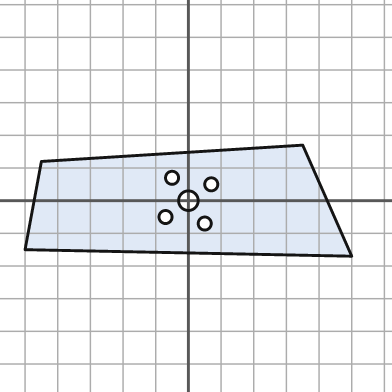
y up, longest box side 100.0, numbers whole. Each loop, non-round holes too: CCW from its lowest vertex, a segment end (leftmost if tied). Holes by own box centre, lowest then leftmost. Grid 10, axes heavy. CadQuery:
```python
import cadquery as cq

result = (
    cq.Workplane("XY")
    .moveTo(50.0, -17.0)
    .lineTo(35.0, 17.0)
    .lineTo(-45.0, 12.0)
    .lineTo(-50.0, -15.0)
    .close()
    .moveTo(5.0, -7.0)
    .circle(2.0)
    .moveTo(-7.0, -5.0)
    .circle(2.0)
    .moveTo(0.0, 0.0)
    .circle(3.0)
    .moveTo(7.0, 5.0)
    .circle(2.0)
    .moveTo(-5.0, 7.0)
    .circle(2.0)
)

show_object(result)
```